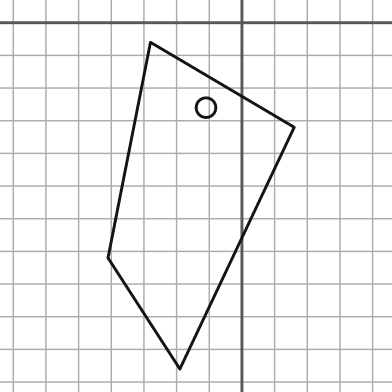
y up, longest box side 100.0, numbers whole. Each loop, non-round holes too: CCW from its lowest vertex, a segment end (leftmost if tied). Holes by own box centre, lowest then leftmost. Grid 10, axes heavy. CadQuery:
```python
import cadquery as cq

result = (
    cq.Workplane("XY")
    .moveTo(-19.0, -106.0)
    .lineTo(16.0, -32.0)
    .lineTo(-28.0, -6.0)
    .lineTo(-41.0, -72.0)
    .close()
    .moveTo(-11.0, -26.0)
    .circle(3.0)
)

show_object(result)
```